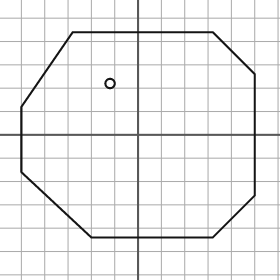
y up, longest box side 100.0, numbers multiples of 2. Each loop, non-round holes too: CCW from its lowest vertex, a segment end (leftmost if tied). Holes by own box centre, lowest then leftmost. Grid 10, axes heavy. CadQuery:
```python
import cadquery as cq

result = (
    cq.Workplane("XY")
    .moveTo(-20.0, -44.0)
    .lineTo(32.0, -44.0)
    .lineTo(50.0, -26.0)
    .lineTo(50.0, 26.0)
    .lineTo(32.0, 44.0)
    .lineTo(-28.0, 44.0)
    .lineTo(-50.0, 12.0)
    .lineTo(-50.0, -16.0)
    .close()
    .moveTo(-12.0, 22.0)
    .circle(2.0)
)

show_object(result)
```